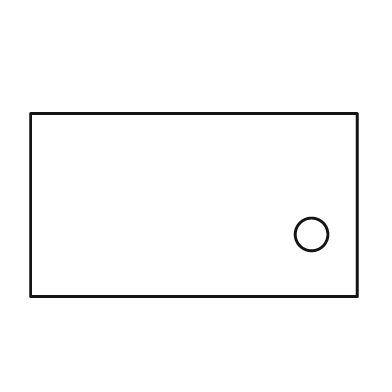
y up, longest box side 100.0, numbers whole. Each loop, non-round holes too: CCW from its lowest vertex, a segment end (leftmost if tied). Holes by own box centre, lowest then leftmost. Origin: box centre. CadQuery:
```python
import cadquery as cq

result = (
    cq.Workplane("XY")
    .moveTo(-50.0, -28.0)
    .lineTo(50.0, -28.0)
    .lineTo(50.0, 28.0)
    .lineTo(-50.0, 28.0)
    .close()
    .moveTo(36.0, -9.0)
    .circle(5.0)
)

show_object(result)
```